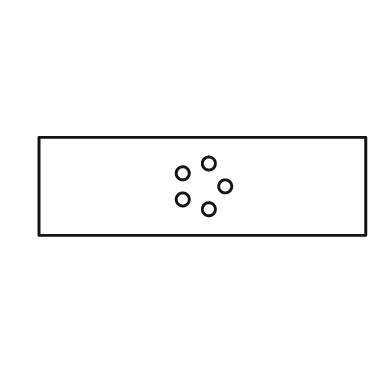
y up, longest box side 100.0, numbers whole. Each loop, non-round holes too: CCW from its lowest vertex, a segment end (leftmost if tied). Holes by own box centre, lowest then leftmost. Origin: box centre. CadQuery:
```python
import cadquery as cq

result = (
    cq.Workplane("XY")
    .moveTo(-50.0, -15.0)
    .lineTo(50.0, -15.0)
    .lineTo(50.0, 15.0)
    .lineTo(-50.0, 15.0)
    .close()
    .moveTo(2.0, -7.0)
    .circle(2.0)
    .moveTo(-6.0, -4.0)
    .circle(2.0)
    .moveTo(7.0, 0.0)
    .circle(2.0)
    .moveTo(-6.0, 4.0)
    .circle(2.0)
    .moveTo(2.0, 7.0)
    .circle(2.0)
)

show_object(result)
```